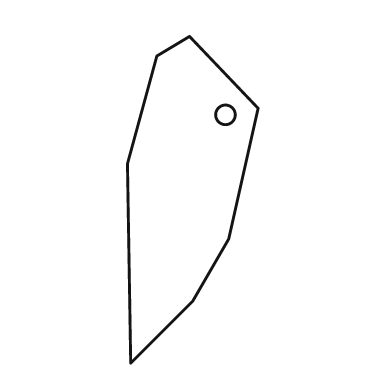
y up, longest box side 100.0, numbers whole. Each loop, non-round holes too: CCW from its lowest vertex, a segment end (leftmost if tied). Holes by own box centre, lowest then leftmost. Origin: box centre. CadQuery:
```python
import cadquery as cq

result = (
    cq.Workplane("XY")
    .moveTo(-19.0, -50.0)
    .lineTo(0.0, -31.0)
    .lineTo(11.0, -12.0)
    .lineTo(20.0, 28.0)
    .lineTo(-1.0, 50.0)
    .lineTo(-11.0, 44.0)
    .lineTo(-20.0, 11.0)
    .close()
    .moveTo(10.0, 26.0)
    .circle(3.0)
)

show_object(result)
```